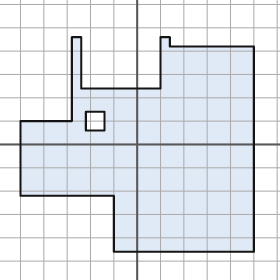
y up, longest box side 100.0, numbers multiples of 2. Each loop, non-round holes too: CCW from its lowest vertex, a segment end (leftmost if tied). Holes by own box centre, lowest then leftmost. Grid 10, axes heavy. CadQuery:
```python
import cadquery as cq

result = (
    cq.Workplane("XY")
    .moveTo(-10.0, -46.0)
    .lineTo(50.0, -46.0)
    .lineTo(50.0, 42.0)
    .lineTo(14.0, 42.0)
    .lineTo(14.0, 46.0)
    .lineTo(10.0, 46.0)
    .lineTo(10.0, 24.0)
    .lineTo(-24.0, 24.0)
    .lineTo(-24.0, 46.0)
    .lineTo(-28.0, 46.0)
    .lineTo(-28.0, 10.0)
    .lineTo(-50.0, 10.0)
    .lineTo(-50.0, -22.0)
    .lineTo(-10.0, -22.0)
    .close()
    .moveTo(-22.0, 6.0)
    .lineTo(-14.0, 6.0)
    .lineTo(-14.0, 14.0)
    .lineTo(-22.0, 14.0)
    .close()
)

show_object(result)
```